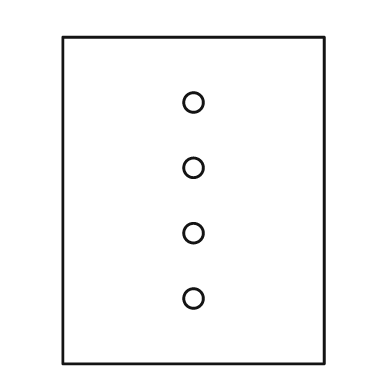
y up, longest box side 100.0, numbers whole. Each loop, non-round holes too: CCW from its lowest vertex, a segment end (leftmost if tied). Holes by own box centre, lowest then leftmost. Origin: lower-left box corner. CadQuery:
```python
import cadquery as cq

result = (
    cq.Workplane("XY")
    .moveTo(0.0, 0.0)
    .lineTo(80.0, 0.0)
    .lineTo(80.0, 100.0)
    .lineTo(0.0, 100.0)
    .close()
    .moveTo(40.0, 20.0)
    .circle(3.0)
    .moveTo(40.0, 40.0)
    .circle(3.0)
    .moveTo(40.0, 60.0)
    .circle(3.0)
    .moveTo(40.0, 80.0)
    .circle(3.0)
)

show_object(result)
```